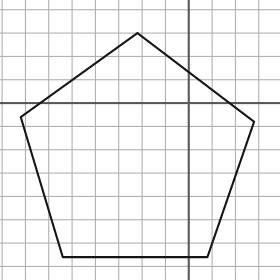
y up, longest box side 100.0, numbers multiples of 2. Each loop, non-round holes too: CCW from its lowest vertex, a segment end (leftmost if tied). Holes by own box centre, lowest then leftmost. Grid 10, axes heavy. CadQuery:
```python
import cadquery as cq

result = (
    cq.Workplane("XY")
    .moveTo(-54.0, -66.0)
    .lineTo(8.0, -66.0)
    .lineTo(28.0, -8.0)
    .lineTo(-22.0, 30.0)
    .lineTo(-72.0, -6.0)
    .close()
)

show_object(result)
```